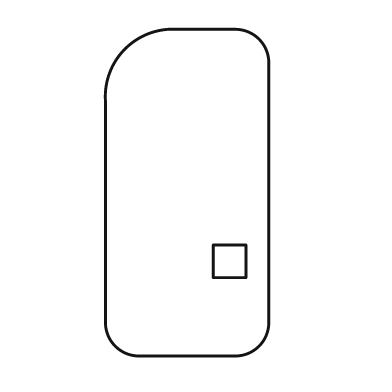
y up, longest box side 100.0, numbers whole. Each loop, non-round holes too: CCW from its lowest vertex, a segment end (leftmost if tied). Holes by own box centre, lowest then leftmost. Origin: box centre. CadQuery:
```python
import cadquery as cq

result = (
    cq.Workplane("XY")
    .moveTo(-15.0, -50.0)
    .lineTo(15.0, -50.0)
    .threePointArc((22.0, -47.0), (25.0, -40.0))
    .lineTo(25.0, 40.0)
    .threePointArc((22.0, 47.0), (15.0, 50.0))
    .lineTo(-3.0, 50.0)
    .threePointArc((-19.0, 44.0), (-25.0, 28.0))
    .lineTo(-25.0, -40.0)
    .threePointArc((-22.0, -47.0), (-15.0, -50.0))
    .close()
    .moveTo(8.0, -26.0)
    .lineTo(18.0, -26.0)
    .lineTo(18.0, -16.0)
    .lineTo(8.0, -16.0)
    .close()
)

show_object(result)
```